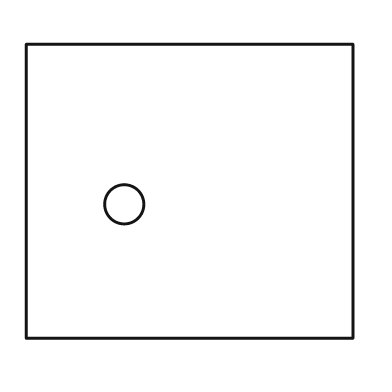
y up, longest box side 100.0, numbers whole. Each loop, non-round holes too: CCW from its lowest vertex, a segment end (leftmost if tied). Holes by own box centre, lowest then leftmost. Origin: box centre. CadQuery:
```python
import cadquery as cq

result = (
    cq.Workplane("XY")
    .moveTo(-50.0, -45.0)
    .lineTo(50.0, -45.0)
    .lineTo(50.0, 45.0)
    .lineTo(-50.0, 45.0)
    .close()
    .moveTo(-20.0, -4.0)
    .circle(6.0)
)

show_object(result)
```